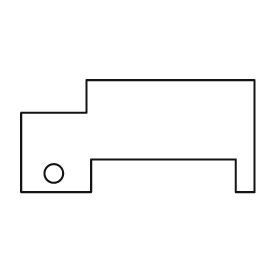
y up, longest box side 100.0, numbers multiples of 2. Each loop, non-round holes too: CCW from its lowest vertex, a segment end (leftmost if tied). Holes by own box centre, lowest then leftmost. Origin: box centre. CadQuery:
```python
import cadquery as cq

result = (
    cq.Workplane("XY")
    .moveTo(-50.0, -24.0)
    .lineTo(-20.0, -24.0)
    .lineTo(-20.0, -10.0)
    .lineTo(42.0, -10.0)
    .lineTo(42.0, -24.0)
    .lineTo(50.0, -24.0)
    .lineTo(50.0, 24.0)
    .lineTo(-22.0, 24.0)
    .lineTo(-22.0, 10.0)
    .lineTo(-50.0, 10.0)
    .close()
    .moveTo(-36.0, -16.0)
    .circle(4.0)
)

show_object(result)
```